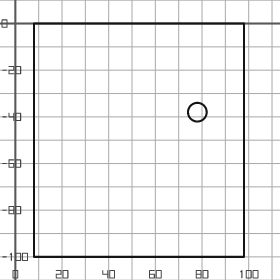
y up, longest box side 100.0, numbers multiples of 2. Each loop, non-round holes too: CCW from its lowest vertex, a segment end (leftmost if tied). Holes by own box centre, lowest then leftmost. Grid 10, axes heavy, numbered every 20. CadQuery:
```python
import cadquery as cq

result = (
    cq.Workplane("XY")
    .moveTo(8.0, -100.0)
    .lineTo(98.0, -100.0)
    .lineTo(98.0, 0.0)
    .lineTo(8.0, 0.0)
    .close()
    .moveTo(78.0, -38.0)
    .circle(4.0)
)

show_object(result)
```